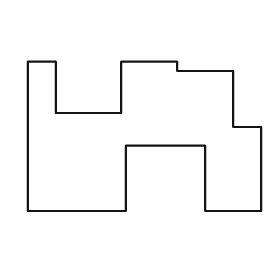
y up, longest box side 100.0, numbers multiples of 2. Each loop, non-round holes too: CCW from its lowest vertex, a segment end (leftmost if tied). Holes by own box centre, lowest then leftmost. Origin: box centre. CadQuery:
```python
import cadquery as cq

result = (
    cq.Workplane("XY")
    .moveTo(-50.0, -32.0)
    .lineTo(-8.0, -32.0)
    .lineTo(-8.0, -4.0)
    .lineTo(26.0, -4.0)
    .lineTo(26.0, -32.0)
    .lineTo(50.0, -32.0)
    .lineTo(50.0, 4.0)
    .lineTo(38.0, 4.0)
    .lineTo(38.0, 28.0)
    .lineTo(14.0, 28.0)
    .lineTo(14.0, 32.0)
    .lineTo(-10.0, 32.0)
    .lineTo(-10.0, 10.0)
    .lineTo(-38.0, 10.0)
    .lineTo(-38.0, 32.0)
    .lineTo(-50.0, 32.0)
    .close()
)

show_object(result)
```